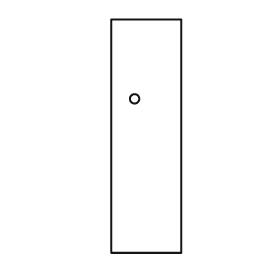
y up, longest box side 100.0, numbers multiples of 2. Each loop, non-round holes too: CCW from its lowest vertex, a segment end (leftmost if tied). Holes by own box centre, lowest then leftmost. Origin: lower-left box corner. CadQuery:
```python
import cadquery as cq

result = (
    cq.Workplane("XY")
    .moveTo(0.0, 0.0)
    .lineTo(30.0, 0.0)
    .lineTo(30.0, 100.0)
    .lineTo(0.0, 100.0)
    .close()
    .moveTo(10.0, 66.0)
    .circle(2.0)
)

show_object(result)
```